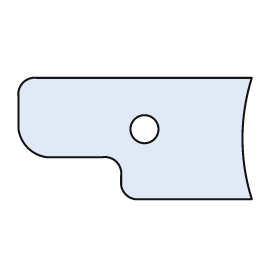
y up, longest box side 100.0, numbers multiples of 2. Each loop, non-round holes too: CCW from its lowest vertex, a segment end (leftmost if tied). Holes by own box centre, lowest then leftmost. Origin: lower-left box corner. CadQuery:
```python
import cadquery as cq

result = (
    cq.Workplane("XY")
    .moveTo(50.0, 0.0)
    .lineTo(100.0, 0.0)
    .threePointArc((96.0, 26.0), (100.0, 52.0))
    .lineTo(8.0, 52.0)
    .threePointArc((2.0, 50.0), (0.0, 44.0))
    .lineTo(0.0, 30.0)
    .threePointArc((4.0, 22.0), (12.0, 18.0))
    .lineTo(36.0, 18.0)
    .threePointArc((42.0, 16.0), (44.0, 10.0))
    .lineTo(44.0, 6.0)
    .threePointArc((46.0, 2.0), (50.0, 0.0))
    .close()
    .moveTo(54.0, 30.0)
    .circle(6.0)
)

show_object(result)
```